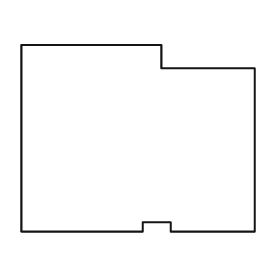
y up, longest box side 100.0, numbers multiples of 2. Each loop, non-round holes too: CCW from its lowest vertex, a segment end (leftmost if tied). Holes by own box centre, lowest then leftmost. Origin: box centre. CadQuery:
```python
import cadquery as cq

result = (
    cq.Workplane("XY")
    .moveTo(-50.0, -40.0)
    .lineTo(2.0, -40.0)
    .lineTo(2.0, -36.0)
    .lineTo(14.0, -36.0)
    .lineTo(14.0, -40.0)
    .lineTo(50.0, -40.0)
    .lineTo(50.0, 30.0)
    .lineTo(10.0, 30.0)
    .lineTo(10.0, 40.0)
    .lineTo(-50.0, 40.0)
    .close()
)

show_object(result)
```